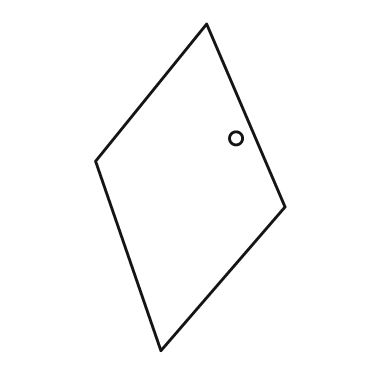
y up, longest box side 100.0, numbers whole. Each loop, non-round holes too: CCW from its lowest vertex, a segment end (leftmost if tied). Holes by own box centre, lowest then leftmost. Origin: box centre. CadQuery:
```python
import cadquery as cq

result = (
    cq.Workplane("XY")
    .moveTo(-9.0, -50.0)
    .lineTo(29.0, -6.0)
    .lineTo(5.0, 50.0)
    .lineTo(-29.0, 8.0)
    .close()
    .moveTo(14.0, 15.0)
    .circle(2.0)
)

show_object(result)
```